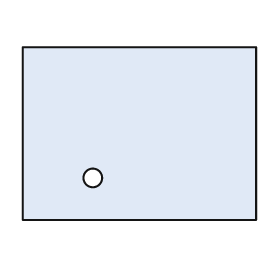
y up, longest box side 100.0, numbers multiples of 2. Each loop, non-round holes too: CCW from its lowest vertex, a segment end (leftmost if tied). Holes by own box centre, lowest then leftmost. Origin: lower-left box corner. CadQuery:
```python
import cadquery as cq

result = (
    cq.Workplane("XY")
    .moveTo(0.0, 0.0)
    .lineTo(100.0, 0.0)
    .lineTo(100.0, 74.0)
    .lineTo(0.0, 74.0)
    .close()
    .moveTo(30.0, 18.0)
    .circle(4.0)
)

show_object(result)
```